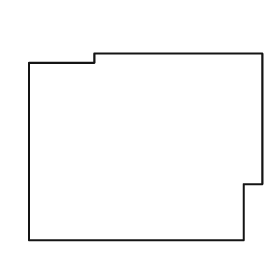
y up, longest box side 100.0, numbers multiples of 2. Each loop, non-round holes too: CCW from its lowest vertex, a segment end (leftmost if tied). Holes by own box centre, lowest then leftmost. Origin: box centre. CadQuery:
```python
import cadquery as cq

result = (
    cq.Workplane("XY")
    .moveTo(-50.0, -40.0)
    .lineTo(42.0, -40.0)
    .lineTo(42.0, -16.0)
    .lineTo(50.0, -16.0)
    .lineTo(50.0, 40.0)
    .lineTo(-22.0, 40.0)
    .lineTo(-22.0, 36.0)
    .lineTo(-50.0, 36.0)
    .close()
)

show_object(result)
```